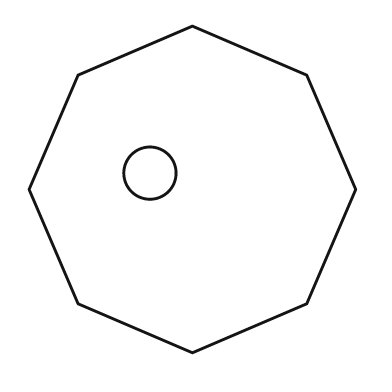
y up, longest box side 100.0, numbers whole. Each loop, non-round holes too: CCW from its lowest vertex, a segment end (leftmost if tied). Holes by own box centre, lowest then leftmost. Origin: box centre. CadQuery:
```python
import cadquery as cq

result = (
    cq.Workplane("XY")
    .moveTo(0.0, -50.0)
    .lineTo(35.0, -35.0)
    .lineTo(50.0, 0.0)
    .lineTo(35.0, 35.0)
    .lineTo(0.0, 50.0)
    .lineTo(-35.0, 35.0)
    .lineTo(-50.0, 0.0)
    .lineTo(-35.0, -35.0)
    .close()
    .moveTo(-13.0, 5.0)
    .circle(8.0)
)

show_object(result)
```